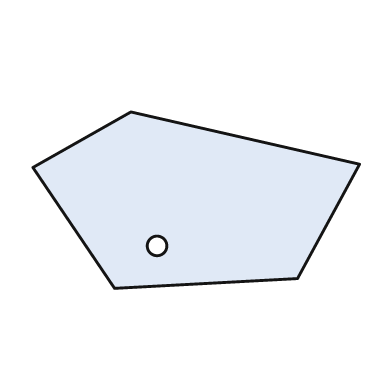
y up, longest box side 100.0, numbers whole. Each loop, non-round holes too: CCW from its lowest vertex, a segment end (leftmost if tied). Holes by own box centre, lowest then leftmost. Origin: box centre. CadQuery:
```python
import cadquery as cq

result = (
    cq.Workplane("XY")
    .moveTo(-25.0, -27.0)
    .lineTo(31.0, -24.0)
    .lineTo(50.0, 11.0)
    .lineTo(-20.0, 27.0)
    .lineTo(-50.0, 10.0)
    .close()
    .moveTo(-12.0, -14.0)
    .circle(3.0)
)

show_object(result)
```